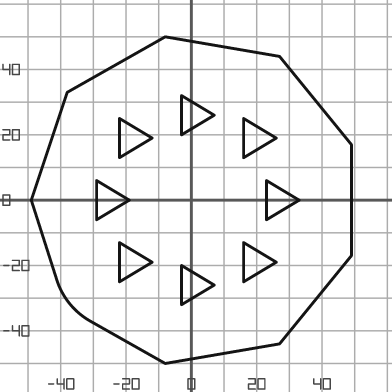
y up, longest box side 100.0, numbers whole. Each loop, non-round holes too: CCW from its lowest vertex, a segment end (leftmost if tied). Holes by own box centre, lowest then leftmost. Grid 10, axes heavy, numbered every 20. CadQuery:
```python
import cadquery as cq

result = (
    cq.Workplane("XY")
    .moveTo(-8.0, -50.0)
    .lineTo(27.0, -44.0)
    .lineTo(49.0, -17.0)
    .lineTo(49.0, 17.0)
    .lineTo(27.0, 44.0)
    .lineTo(-8.0, 50.0)
    .lineTo(-38.0, 33.0)
    .lineTo(-49.0, 0.0)
    .lineTo(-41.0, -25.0)
    .threePointArc((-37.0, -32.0), (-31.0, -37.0))
    .close()
    .moveTo(-3.0, -32.0)
    .lineTo(7.0, -26.0)
    .lineTo(-3.0, -20.0)
    .close()
    .moveTo(-22.0, -25.0)
    .lineTo(-12.0, -19.0)
    .lineTo(-22.0, -13.0)
    .close()
    .moveTo(16.0, -25.0)
    .lineTo(26.0, -19.0)
    .lineTo(16.0, -13.0)
    .close()
    .moveTo(-29.0, -6.0)
    .lineTo(-19.0, 0.0)
    .lineTo(-29.0, 6.0)
    .close()
    .moveTo(23.0, -6.0)
    .lineTo(33.0, 0.0)
    .lineTo(23.0, 6.0)
    .close()
    .moveTo(-22.0, 13.0)
    .lineTo(-12.0, 19.0)
    .lineTo(-22.0, 25.0)
    .close()
    .moveTo(16.0, 13.0)
    .lineTo(26.0, 19.0)
    .lineTo(16.0, 25.0)
    .close()
    .moveTo(-3.0, 20.0)
    .lineTo(7.0, 26.0)
    .lineTo(-3.0, 32.0)
    .close()
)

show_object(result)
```